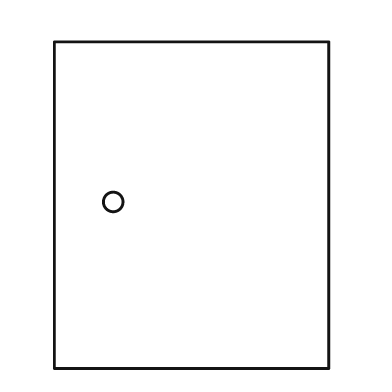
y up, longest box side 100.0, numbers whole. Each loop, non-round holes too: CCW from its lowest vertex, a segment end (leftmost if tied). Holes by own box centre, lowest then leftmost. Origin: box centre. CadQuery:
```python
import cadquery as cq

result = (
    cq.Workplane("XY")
    .moveTo(-42.0, -50.0)
    .lineTo(42.0, -50.0)
    .lineTo(42.0, 50.0)
    .lineTo(-42.0, 50.0)
    .close()
    .moveTo(-24.0, 1.0)
    .circle(3.0)
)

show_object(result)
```